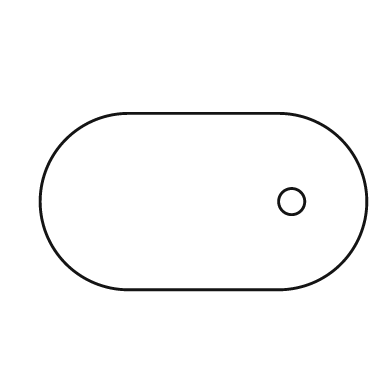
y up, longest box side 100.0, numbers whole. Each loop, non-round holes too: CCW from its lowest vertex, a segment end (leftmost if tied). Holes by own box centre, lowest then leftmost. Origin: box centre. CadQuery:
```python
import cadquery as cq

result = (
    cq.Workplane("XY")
    .moveTo(-23.0, -27.0)
    .lineTo(23.0, -27.0)
    .threePointArc((50.0, 0.0), (23.0, 27.0))
    .lineTo(-23.0, 27.0)
    .threePointArc((-50.0, 0.0), (-23.0, -27.0))
    .close()
    .moveTo(27.0, 0.0)
    .circle(4.0)
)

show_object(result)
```